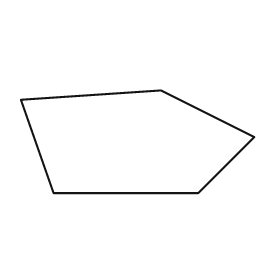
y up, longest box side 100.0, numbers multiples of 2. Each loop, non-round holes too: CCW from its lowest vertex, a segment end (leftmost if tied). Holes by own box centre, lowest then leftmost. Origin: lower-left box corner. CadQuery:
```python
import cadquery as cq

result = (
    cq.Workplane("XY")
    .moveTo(14.0, 0.0)
    .lineTo(76.0, 0.0)
    .lineTo(100.0, 24.0)
    .lineTo(60.0, 44.0)
    .lineTo(0.0, 40.0)
    .close()
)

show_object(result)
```